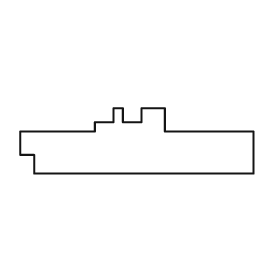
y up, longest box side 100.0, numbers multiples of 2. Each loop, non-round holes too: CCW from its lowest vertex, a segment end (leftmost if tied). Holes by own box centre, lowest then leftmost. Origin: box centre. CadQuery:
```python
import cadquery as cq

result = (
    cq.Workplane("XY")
    .moveTo(-44.0, -14.0)
    .lineTo(50.0, -14.0)
    .lineTo(50.0, 4.0)
    .lineTo(12.0, 4.0)
    .lineTo(12.0, 14.0)
    .lineTo(2.0, 14.0)
    .lineTo(2.0, 8.0)
    .lineTo(-6.0, 8.0)
    .lineTo(-6.0, 14.0)
    .lineTo(-10.0, 14.0)
    .lineTo(-10.0, 8.0)
    .lineTo(-18.0, 8.0)
    .lineTo(-18.0, 4.0)
    .lineTo(-50.0, 4.0)
    .lineTo(-50.0, -6.0)
    .lineTo(-44.0, -6.0)
    .close()
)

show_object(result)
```